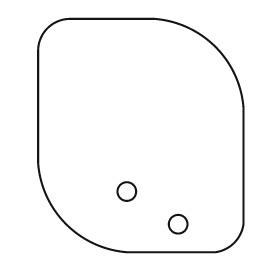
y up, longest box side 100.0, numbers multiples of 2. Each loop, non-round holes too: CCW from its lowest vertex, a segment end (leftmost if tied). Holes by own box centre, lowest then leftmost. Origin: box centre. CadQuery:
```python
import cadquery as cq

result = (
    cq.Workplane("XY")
    .moveTo(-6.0, -50.0)
    .lineTo(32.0, -50.0)
    .threePointArc((40.0, -46.0), (44.0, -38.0))
    .lineTo(44.0, 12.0)
    .threePointArc((32.0, 38.0), (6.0, 50.0))
    .lineTo(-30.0, 50.0)
    .threePointArc((-40.0, 46.0), (-44.0, 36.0))
    .lineTo(-44.0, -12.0)
    .threePointArc((-32.0, -38.0), (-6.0, -50.0))
    .close()
    .moveTo(16.0, -38.0)
    .circle(4.0)
    .moveTo(-6.0, -24.0)
    .circle(4.0)
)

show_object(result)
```